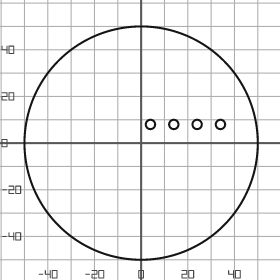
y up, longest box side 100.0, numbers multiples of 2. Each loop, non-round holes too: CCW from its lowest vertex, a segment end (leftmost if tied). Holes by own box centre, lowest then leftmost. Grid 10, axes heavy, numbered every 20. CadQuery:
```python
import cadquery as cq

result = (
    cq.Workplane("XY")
    .moveTo(0.0, 0.0)
    .circle(50.0)
    .moveTo(4.0, 8.0)
    .circle(2.0)
    .moveTo(14.0, 8.0)
    .circle(2.0)
    .moveTo(24.0, 8.0)
    .circle(2.0)
    .moveTo(34.0, 8.0)
    .circle(2.0)
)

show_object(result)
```